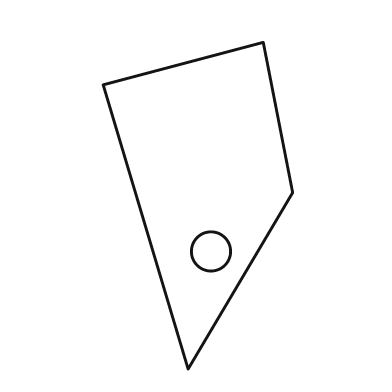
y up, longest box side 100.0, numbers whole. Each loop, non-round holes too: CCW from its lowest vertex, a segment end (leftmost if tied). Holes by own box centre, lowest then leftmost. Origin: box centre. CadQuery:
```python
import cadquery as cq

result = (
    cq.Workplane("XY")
    .moveTo(-3.0, -50.0)
    .lineTo(29.0, 4.0)
    .lineTo(20.0, 50.0)
    .lineTo(-29.0, 37.0)
    .close()
    .moveTo(4.0, -14.0)
    .circle(6.0)
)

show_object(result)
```